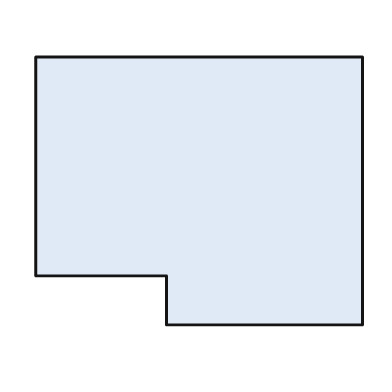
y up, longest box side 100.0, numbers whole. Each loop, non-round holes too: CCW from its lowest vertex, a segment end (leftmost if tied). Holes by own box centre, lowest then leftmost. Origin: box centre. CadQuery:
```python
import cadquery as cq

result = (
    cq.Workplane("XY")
    .moveTo(-10.0, -41.0)
    .lineTo(50.0, -41.0)
    .lineTo(50.0, 41.0)
    .lineTo(-50.0, 41.0)
    .lineTo(-50.0, -26.0)
    .lineTo(-10.0, -26.0)
    .close()
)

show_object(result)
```